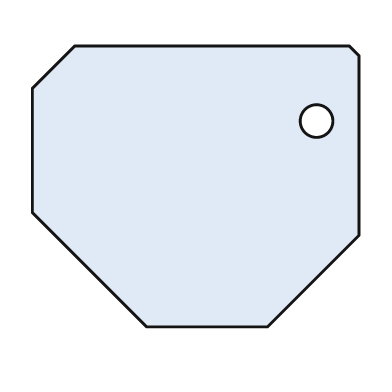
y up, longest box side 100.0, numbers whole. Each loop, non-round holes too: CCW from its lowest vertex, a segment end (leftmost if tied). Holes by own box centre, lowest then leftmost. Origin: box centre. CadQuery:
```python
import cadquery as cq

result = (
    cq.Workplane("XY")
    .moveTo(-15.0, -43.0)
    .lineTo(22.0, -43.0)
    .lineTo(50.0, -15.0)
    .lineTo(50.0, 40.0)
    .lineTo(47.0, 43.0)
    .lineTo(-37.0, 43.0)
    .lineTo(-50.0, 30.0)
    .lineTo(-50.0, -8.0)
    .close()
    .moveTo(37.0, 20.0)
    .circle(5.0)
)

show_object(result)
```